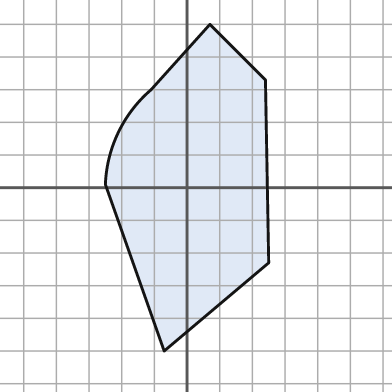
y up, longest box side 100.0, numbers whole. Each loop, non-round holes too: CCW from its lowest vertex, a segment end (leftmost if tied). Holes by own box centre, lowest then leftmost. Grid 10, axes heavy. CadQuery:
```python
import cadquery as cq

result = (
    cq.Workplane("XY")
    .moveTo(-7.0, -50.0)
    .lineTo(25.0, -23.0)
    .lineTo(24.0, 33.0)
    .lineTo(7.0, 50.0)
    .lineTo(-11.0, 30.0)
    .threePointArc((-21.0, 17.0), (-25.0, 1.0))
    .close()
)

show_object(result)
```